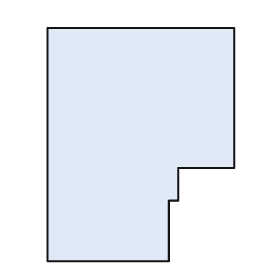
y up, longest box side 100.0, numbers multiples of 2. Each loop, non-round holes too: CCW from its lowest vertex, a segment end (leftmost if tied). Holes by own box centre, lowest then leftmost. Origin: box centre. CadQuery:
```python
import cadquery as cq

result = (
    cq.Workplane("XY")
    .moveTo(-40.0, -50.0)
    .lineTo(12.0, -50.0)
    .lineTo(12.0, -24.0)
    .lineTo(16.0, -24.0)
    .lineTo(16.0, -10.0)
    .lineTo(40.0, -10.0)
    .lineTo(40.0, 50.0)
    .lineTo(-40.0, 50.0)
    .close()
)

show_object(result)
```